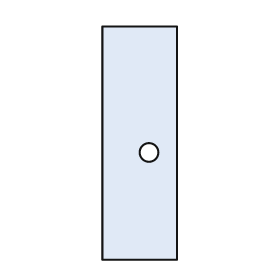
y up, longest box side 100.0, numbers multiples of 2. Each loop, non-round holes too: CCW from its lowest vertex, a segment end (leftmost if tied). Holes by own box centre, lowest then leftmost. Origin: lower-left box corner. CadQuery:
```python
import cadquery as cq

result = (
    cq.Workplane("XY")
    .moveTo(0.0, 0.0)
    .lineTo(32.0, 0.0)
    .lineTo(32.0, 100.0)
    .lineTo(0.0, 100.0)
    .close()
    .moveTo(20.0, 46.0)
    .circle(4.0)
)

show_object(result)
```